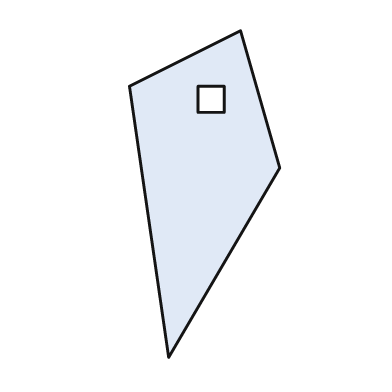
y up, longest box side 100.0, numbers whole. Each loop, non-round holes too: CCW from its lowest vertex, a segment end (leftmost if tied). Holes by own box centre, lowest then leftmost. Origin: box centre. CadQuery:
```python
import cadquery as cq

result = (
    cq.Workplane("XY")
    .moveTo(-11.0, -50.0)
    .lineTo(23.0, 8.0)
    .lineTo(11.0, 50.0)
    .lineTo(-23.0, 33.0)
    .close()
    .moveTo(-2.0, 25.0)
    .lineTo(6.0, 25.0)
    .lineTo(6.0, 33.0)
    .lineTo(-2.0, 33.0)
    .close()
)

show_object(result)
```